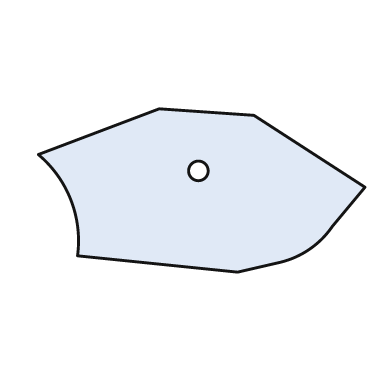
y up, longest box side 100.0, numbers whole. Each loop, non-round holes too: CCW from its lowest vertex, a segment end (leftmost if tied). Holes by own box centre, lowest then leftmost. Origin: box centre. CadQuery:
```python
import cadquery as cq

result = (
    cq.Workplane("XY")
    .moveTo(11.0, -25.0)
    .lineTo(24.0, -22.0)
    .threePointArc((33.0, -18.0), (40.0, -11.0))
    .lineTo(50.0, 1.0)
    .lineTo(16.0, 23.0)
    .lineTo(-13.0, 25.0)
    .lineTo(-50.0, 11.0)
    .threePointArc((-40.0, -3.0), (-38.0, -20.0))
    .close()
    .moveTo(-1.0, 6.0)
    .circle(3.0)
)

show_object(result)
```